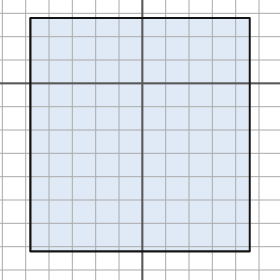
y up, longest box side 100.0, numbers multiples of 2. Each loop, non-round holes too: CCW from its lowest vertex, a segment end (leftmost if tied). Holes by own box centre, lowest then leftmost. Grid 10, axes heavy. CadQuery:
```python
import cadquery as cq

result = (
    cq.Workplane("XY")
    .moveTo(-48.0, -72.0)
    .lineTo(46.0, -72.0)
    .lineTo(46.0, 28.0)
    .lineTo(-48.0, 28.0)
    .close()
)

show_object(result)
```